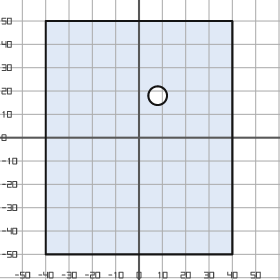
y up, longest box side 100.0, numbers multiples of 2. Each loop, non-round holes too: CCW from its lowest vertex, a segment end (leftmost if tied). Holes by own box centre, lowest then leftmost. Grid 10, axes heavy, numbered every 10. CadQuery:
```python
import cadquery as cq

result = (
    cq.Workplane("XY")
    .moveTo(-40.0, -50.0)
    .lineTo(40.0, -50.0)
    .lineTo(40.0, 50.0)
    .lineTo(-40.0, 50.0)
    .close()
    .moveTo(8.0, 18.0)
    .circle(4.0)
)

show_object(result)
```